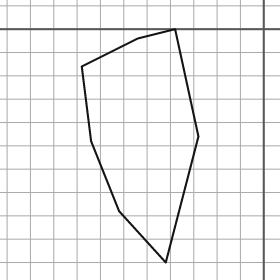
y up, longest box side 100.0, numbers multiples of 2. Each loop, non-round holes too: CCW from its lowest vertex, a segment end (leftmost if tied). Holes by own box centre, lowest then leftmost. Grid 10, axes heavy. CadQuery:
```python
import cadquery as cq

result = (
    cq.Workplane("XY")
    .moveTo(-42.0, -100.0)
    .lineTo(-28.0, -46.0)
    .lineTo(-38.0, 0.0)
    .lineTo(-54.0, -4.0)
    .lineTo(-78.0, -16.0)
    .lineTo(-74.0, -48.0)
    .lineTo(-62.0, -78.0)
    .close()
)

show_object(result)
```